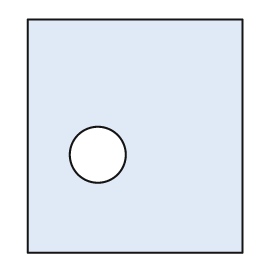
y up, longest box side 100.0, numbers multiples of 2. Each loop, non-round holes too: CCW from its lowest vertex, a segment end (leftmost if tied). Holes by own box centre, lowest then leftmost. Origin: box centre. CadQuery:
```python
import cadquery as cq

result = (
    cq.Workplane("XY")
    .moveTo(-46.0, -50.0)
    .lineTo(46.0, -50.0)
    .lineTo(46.0, 50.0)
    .lineTo(-46.0, 50.0)
    .close()
    .moveTo(-16.0, -8.0)
    .circle(12.0)
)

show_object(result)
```